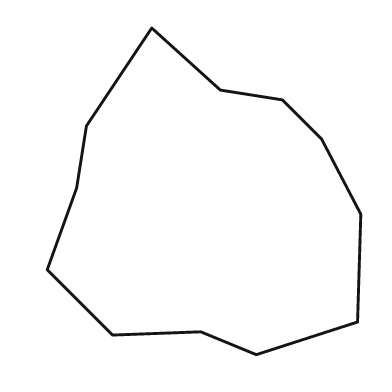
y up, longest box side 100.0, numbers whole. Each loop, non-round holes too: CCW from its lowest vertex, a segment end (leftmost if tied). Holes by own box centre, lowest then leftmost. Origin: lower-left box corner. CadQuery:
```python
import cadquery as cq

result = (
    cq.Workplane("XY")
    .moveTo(64.0, 0.0)
    .lineTo(95.0, 10.0)
    .lineTo(96.0, 43.0)
    .lineTo(84.0, 66.0)
    .lineTo(72.0, 78.0)
    .lineTo(53.0, 81.0)
    .lineTo(32.0, 100.0)
    .lineTo(12.0, 70.0)
    .lineTo(9.0, 51.0)
    .lineTo(0.0, 26.0)
    .lineTo(20.0, 6.0)
    .lineTo(47.0, 7.0)
    .close()
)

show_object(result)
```